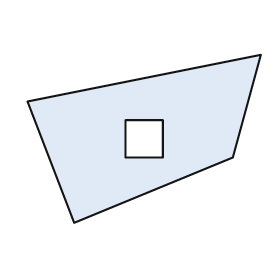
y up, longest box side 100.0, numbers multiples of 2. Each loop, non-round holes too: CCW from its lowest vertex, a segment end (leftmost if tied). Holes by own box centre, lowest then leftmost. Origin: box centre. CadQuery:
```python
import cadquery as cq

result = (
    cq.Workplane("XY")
    .moveTo(-30.0, -36.0)
    .lineTo(38.0, -8.0)
    .lineTo(50.0, 36.0)
    .lineTo(-50.0, 16.0)
    .close()
    .moveTo(-8.0, -8.0)
    .lineTo(8.0, -8.0)
    .lineTo(8.0, 8.0)
    .lineTo(-8.0, 8.0)
    .close()
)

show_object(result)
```